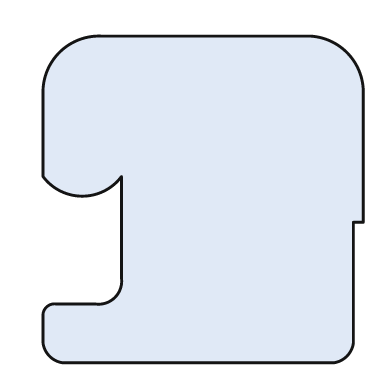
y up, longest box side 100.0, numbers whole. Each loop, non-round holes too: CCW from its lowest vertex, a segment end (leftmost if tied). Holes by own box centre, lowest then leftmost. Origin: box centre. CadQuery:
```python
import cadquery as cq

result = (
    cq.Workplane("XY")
    .moveTo(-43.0, -50.0)
    .lineTo(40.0, -50.0)
    .threePointArc((44.0, -48.0), (46.0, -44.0))
    .lineTo(46.0, -7.0)
    .lineTo(49.0, -7.0)
    .lineTo(49.0, 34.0)
    .threePointArc((44.0, 45.0), (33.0, 50.0))
    .lineTo(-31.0, 50.0)
    .threePointArc((-44.0, 45.0), (-49.0, 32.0))
    .lineTo(-49.0, 7.0)
    .threePointArc((-37.0, 1.0), (-25.0, 7.0))
    .lineTo(-25.0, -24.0)
    .threePointArc((-27.0, -30.0), (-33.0, -32.0))
    .lineTo(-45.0, -32.0)
    .threePointArc((-48.0, -33.0), (-49.0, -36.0))
    .lineTo(-49.0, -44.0)
    .threePointArc((-47.0, -48.0), (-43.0, -50.0))
    .close()
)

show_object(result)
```